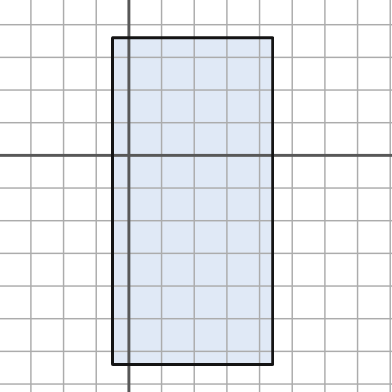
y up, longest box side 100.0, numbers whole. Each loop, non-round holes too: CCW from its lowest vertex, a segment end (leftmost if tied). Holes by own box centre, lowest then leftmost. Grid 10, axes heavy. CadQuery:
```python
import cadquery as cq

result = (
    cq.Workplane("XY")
    .moveTo(-5.0, -64.0)
    .lineTo(44.0, -64.0)
    .lineTo(44.0, 36.0)
    .lineTo(-5.0, 36.0)
    .close()
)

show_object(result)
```